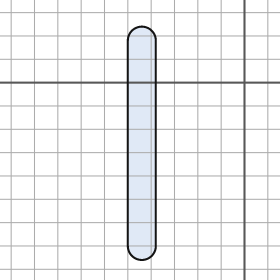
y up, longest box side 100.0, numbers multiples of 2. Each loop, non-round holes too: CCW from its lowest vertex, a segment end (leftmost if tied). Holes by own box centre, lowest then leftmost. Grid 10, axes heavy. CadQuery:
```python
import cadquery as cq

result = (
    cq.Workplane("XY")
    .moveTo(-50.0, -70.0)
    .threePointArc((-44.0, -76.0), (-38.0, -70.0))
    .lineTo(-38.0, 18.0)
    .threePointArc((-44.0, 24.0), (-50.0, 18.0))
    .close()
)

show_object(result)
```